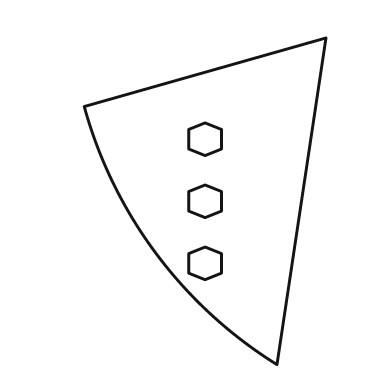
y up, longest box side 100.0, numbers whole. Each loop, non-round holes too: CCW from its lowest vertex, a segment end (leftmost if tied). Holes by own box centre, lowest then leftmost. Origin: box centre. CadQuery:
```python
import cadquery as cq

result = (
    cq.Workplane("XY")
    .moveTo(22.0, -50.0)
    .lineTo(37.0, 50.0)
    .lineTo(-37.0, 29.0)
    .threePointArc((-15.0, -16.0), (22.0, -50.0))
    .close()
    .moveTo(0.0, -24.0)
    .lineTo(5.0, -22.0)
    .lineTo(5.0, -16.0)
    .lineTo(0.0, -14.0)
    .lineTo(-5.0, -16.0)
    .lineTo(-5.0, -22.0)
    .close()
    .moveTo(0.0, -5.0)
    .lineTo(5.0, -3.0)
    .lineTo(5.0, 3.0)
    .lineTo(0.0, 5.0)
    .lineTo(-5.0, 3.0)
    .lineTo(-5.0, -3.0)
    .close()
    .moveTo(0.0, 14.0)
    .lineTo(5.0, 16.0)
    .lineTo(5.0, 22.0)
    .lineTo(0.0, 24.0)
    .lineTo(-5.0, 22.0)
    .lineTo(-5.0, 16.0)
    .close()
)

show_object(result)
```